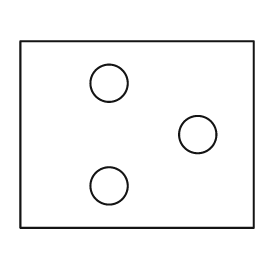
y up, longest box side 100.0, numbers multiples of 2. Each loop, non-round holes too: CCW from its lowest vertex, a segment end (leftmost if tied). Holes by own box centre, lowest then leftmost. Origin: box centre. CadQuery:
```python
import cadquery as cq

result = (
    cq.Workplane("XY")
    .moveTo(-50.0, -40.0)
    .lineTo(50.0, -40.0)
    .lineTo(50.0, 40.0)
    .lineTo(-50.0, 40.0)
    .close()
    .moveTo(-12.0, -22.0)
    .circle(8.0)
    .moveTo(26.0, 0.0)
    .circle(8.0)
    .moveTo(-12.0, 22.0)
    .circle(8.0)
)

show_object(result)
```